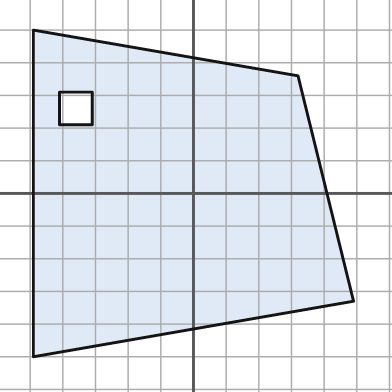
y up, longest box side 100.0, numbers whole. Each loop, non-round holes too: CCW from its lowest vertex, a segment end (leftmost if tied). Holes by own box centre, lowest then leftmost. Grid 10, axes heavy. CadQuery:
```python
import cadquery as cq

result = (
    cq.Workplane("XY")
    .moveTo(-49.0, -50.0)
    .lineTo(49.0, -33.0)
    .lineTo(32.0, 36.0)
    .lineTo(-49.0, 50.0)
    .close()
    .moveTo(-41.0, 21.0)
    .lineTo(-31.0, 21.0)
    .lineTo(-31.0, 31.0)
    .lineTo(-41.0, 31.0)
    .close()
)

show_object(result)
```